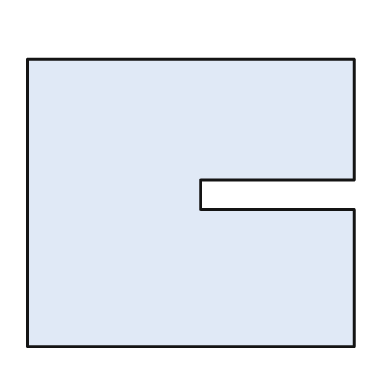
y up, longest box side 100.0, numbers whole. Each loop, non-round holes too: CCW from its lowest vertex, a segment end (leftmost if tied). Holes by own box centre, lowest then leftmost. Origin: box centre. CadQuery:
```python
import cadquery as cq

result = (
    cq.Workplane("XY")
    .moveTo(-50.0, -44.0)
    .lineTo(50.0, -44.0)
    .lineTo(50.0, -2.0)
    .lineTo(3.0, -2.0)
    .lineTo(3.0, 7.0)
    .lineTo(50.0, 7.0)
    .lineTo(50.0, 44.0)
    .lineTo(-50.0, 44.0)
    .close()
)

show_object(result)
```